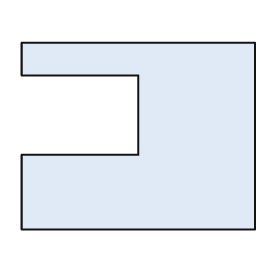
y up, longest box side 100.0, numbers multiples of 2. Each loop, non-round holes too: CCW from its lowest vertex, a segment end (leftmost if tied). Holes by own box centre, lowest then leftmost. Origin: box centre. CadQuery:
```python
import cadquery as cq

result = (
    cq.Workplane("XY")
    .moveTo(-50.0, -40.0)
    .lineTo(50.0, -40.0)
    .lineTo(50.0, 40.0)
    .lineTo(-50.0, 40.0)
    .lineTo(-50.0, 26.0)
    .lineTo(0.0, 26.0)
    .lineTo(0.0, -8.0)
    .lineTo(-50.0, -8.0)
    .close()
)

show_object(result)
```